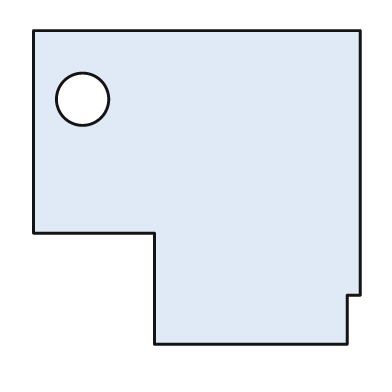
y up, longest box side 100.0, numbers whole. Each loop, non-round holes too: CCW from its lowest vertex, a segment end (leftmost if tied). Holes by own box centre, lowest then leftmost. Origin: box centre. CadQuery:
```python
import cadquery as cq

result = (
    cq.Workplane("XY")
    .moveTo(-13.0, -48.0)
    .lineTo(46.0, -48.0)
    .lineTo(46.0, -33.0)
    .lineTo(50.0, -33.0)
    .lineTo(50.0, 48.0)
    .lineTo(-50.0, 48.0)
    .lineTo(-50.0, -14.0)
    .lineTo(-13.0, -14.0)
    .close()
    .moveTo(-35.0, 27.0)
    .circle(8.0)
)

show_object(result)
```